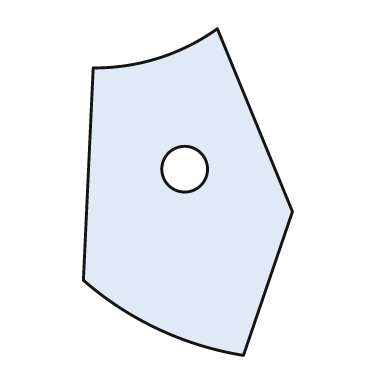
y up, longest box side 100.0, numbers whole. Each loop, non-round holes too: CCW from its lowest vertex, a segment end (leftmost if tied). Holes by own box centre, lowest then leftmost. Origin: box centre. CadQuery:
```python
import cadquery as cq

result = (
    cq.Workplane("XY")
    .moveTo(17.0, -50.0)
    .lineTo(32.0, -6.0)
    .lineTo(9.0, 50.0)
    .threePointArc((-9.0, 41.0), (-29.0, 38.0))
    .lineTo(-32.0, -27.0)
    .threePointArc((-9.0, -42.0), (17.0, -50.0))
    .close()
    .moveTo(-1.0, 7.0)
    .circle(7.0)
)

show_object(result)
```